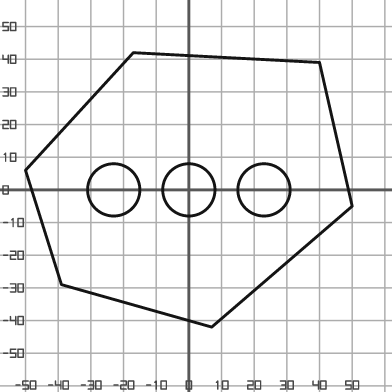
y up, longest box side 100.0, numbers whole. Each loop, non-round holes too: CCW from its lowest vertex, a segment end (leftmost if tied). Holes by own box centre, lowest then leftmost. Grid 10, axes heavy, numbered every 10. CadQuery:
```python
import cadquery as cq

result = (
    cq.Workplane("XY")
    .moveTo(7.0, -42.0)
    .lineTo(50.0, -5.0)
    .lineTo(40.0, 39.0)
    .lineTo(-17.0, 42.0)
    .lineTo(-50.0, 6.0)
    .lineTo(-39.0, -29.0)
    .close()
    .moveTo(-23.0, 0.0)
    .circle(8.0)
    .moveTo(0.0, 0.0)
    .circle(8.0)
    .moveTo(23.0, 0.0)
    .circle(8.0)
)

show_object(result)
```